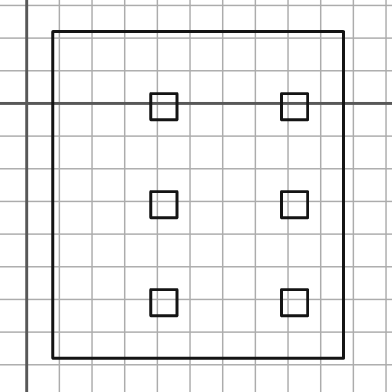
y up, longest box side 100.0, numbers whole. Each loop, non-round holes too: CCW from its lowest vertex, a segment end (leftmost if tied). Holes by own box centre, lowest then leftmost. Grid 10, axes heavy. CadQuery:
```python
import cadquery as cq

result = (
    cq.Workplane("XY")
    .moveTo(8.0, -78.0)
    .lineTo(97.0, -78.0)
    .lineTo(97.0, 22.0)
    .lineTo(8.0, 22.0)
    .close()
    .moveTo(38.0, -65.0)
    .lineTo(46.0, -65.0)
    .lineTo(46.0, -57.0)
    .lineTo(38.0, -57.0)
    .close()
    .moveTo(78.0, -65.0)
    .lineTo(86.0, -65.0)
    .lineTo(86.0, -57.0)
    .lineTo(78.0, -57.0)
    .close()
    .moveTo(38.0, -35.0)
    .lineTo(46.0, -35.0)
    .lineTo(46.0, -27.0)
    .lineTo(38.0, -27.0)
    .close()
    .moveTo(78.0, -35.0)
    .lineTo(86.0, -35.0)
    .lineTo(86.0, -27.0)
    .lineTo(78.0, -27.0)
    .close()
    .moveTo(38.0, -5.0)
    .lineTo(46.0, -5.0)
    .lineTo(46.0, 3.0)
    .lineTo(38.0, 3.0)
    .close()
    .moveTo(78.0, -5.0)
    .lineTo(86.0, -5.0)
    .lineTo(86.0, 3.0)
    .lineTo(78.0, 3.0)
    .close()
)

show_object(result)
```